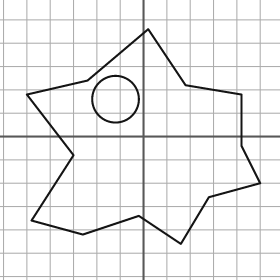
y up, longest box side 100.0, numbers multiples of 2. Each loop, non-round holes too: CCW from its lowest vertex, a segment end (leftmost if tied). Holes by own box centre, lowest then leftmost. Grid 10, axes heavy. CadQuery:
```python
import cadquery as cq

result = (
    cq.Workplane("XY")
    .moveTo(16.0, -46.0)
    .lineTo(28.0, -26.0)
    .lineTo(50.0, -20.0)
    .lineTo(42.0, -4.0)
    .lineTo(42.0, 18.0)
    .lineTo(18.0, 22.0)
    .lineTo(2.0, 46.0)
    .lineTo(-24.0, 24.0)
    .lineTo(-50.0, 18.0)
    .lineTo(-30.0, -8.0)
    .lineTo(-48.0, -36.0)
    .lineTo(-26.0, -42.0)
    .lineTo(-2.0, -34.0)
    .close()
    .moveTo(-12.0, 16.0)
    .circle(10.0)
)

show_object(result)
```